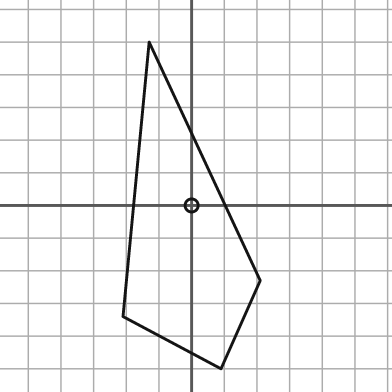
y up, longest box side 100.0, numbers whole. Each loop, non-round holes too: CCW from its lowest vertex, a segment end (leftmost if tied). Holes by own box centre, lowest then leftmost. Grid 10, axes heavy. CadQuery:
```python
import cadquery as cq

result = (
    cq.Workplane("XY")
    .moveTo(9.0, -50.0)
    .lineTo(21.0, -23.0)
    .lineTo(-13.0, 50.0)
    .lineTo(-21.0, -34.0)
    .close()
    .moveTo(0.0, 0.0)
    .circle(2.0)
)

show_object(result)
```